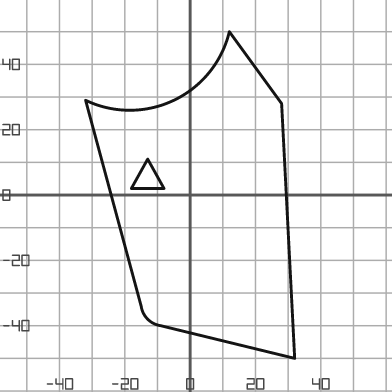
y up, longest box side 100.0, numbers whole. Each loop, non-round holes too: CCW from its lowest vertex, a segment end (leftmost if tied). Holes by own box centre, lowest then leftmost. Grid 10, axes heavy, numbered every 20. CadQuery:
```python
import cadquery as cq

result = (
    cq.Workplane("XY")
    .moveTo(32.0, -50.0)
    .lineTo(28.0, 28.0)
    .lineTo(12.0, 50.0)
    .threePointArc((-5.0, 29.0), (-32.0, 29.0))
    .lineTo(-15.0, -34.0)
    .threePointArc((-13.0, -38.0), (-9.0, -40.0))
    .close()
    .moveTo(-18.0, 2.0)
    .lineTo(-8.0, 2.0)
    .lineTo(-13.0, 11.0)
    .close()
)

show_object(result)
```